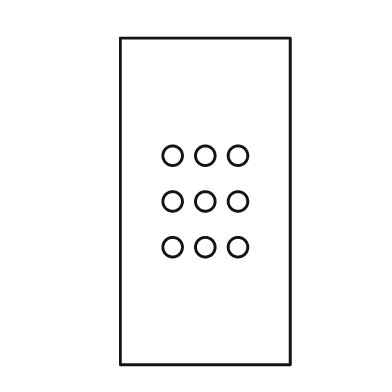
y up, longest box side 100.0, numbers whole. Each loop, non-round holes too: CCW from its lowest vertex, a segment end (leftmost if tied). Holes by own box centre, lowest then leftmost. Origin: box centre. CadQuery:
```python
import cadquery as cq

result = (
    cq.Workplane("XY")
    .moveTo(-26.0, -50.0)
    .lineTo(26.0, -50.0)
    .lineTo(26.0, 50.0)
    .lineTo(-26.0, 50.0)
    .close()
    .moveTo(-10.0, -14.0)
    .circle(3.0)
    .moveTo(0.0, -14.0)
    .circle(3.0)
    .moveTo(10.0, -14.0)
    .circle(3.0)
    .moveTo(-10.0, 0.0)
    .circle(3.0)
    .moveTo(0.0, 0.0)
    .circle(3.0)
    .moveTo(10.0, 0.0)
    .circle(3.0)
    .moveTo(-10.0, 14.0)
    .circle(3.0)
    .moveTo(0.0, 14.0)
    .circle(3.0)
    .moveTo(10.0, 14.0)
    .circle(3.0)
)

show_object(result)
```